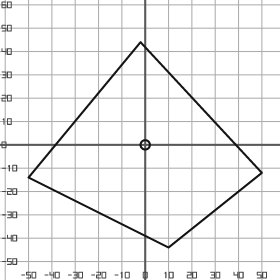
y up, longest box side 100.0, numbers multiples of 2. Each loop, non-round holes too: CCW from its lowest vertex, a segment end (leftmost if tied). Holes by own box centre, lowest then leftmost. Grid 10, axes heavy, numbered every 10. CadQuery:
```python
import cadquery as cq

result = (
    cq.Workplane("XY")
    .moveTo(10.0, -44.0)
    .lineTo(50.0, -12.0)
    .lineTo(-2.0, 44.0)
    .lineTo(-50.0, -14.0)
    .close()
    .moveTo(0.0, 0.0)
    .circle(2.0)
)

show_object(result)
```